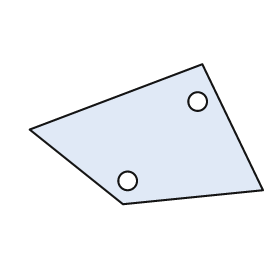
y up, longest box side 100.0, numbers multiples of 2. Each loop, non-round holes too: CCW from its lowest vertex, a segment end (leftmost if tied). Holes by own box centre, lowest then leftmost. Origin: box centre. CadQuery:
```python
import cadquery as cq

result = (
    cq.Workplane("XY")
    .moveTo(-10.0, -30.0)
    .lineTo(50.0, -24.0)
    .lineTo(24.0, 30.0)
    .lineTo(-50.0, 2.0)
    .close()
    .moveTo(-8.0, -20.0)
    .circle(4.0)
    .moveTo(22.0, 14.0)
    .circle(4.0)
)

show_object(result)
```